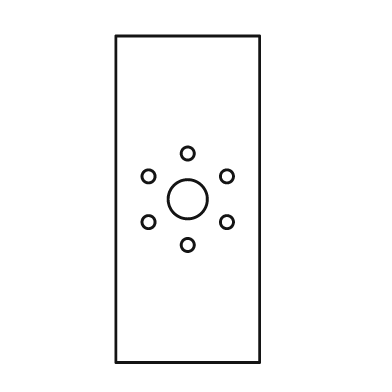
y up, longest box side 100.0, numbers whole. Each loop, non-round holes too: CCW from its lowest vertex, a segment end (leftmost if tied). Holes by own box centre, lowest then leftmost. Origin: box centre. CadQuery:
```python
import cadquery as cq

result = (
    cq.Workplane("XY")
    .moveTo(-22.0, -50.0)
    .lineTo(22.0, -50.0)
    .lineTo(22.0, 50.0)
    .lineTo(-22.0, 50.0)
    .close()
    .moveTo(0.0, -14.0)
    .circle(2.0)
    .moveTo(-12.0, -7.0)
    .circle(2.0)
    .moveTo(12.0, -7.0)
    .circle(2.0)
    .moveTo(0.0, 0.0)
    .circle(6.0)
    .moveTo(-12.0, 7.0)
    .circle(2.0)
    .moveTo(12.0, 7.0)
    .circle(2.0)
    .moveTo(0.0, 14.0)
    .circle(2.0)
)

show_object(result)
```